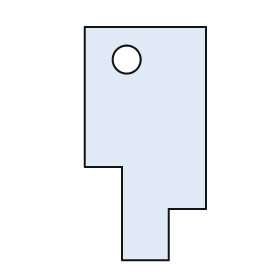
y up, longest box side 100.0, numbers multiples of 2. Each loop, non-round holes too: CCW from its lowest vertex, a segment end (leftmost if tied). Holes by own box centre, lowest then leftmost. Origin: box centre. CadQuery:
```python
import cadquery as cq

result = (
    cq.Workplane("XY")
    .moveTo(-10.0, -50.0)
    .lineTo(10.0, -50.0)
    .lineTo(10.0, -28.0)
    .lineTo(26.0, -28.0)
    .lineTo(26.0, 50.0)
    .lineTo(-26.0, 50.0)
    .lineTo(-26.0, -10.0)
    .lineTo(-10.0, -10.0)
    .close()
    .moveTo(-8.0, 36.0)
    .circle(6.0)
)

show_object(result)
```